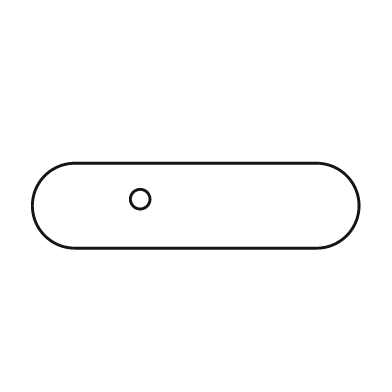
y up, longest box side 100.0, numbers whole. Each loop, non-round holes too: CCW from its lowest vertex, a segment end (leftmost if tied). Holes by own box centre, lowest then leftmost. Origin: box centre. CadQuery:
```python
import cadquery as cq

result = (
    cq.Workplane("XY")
    .moveTo(-37.0, -13.0)
    .lineTo(37.0, -13.0)
    .threePointArc((50.0, 0.0), (37.0, 13.0))
    .lineTo(-37.0, 13.0)
    .threePointArc((-50.0, 0.0), (-37.0, -13.0))
    .close()
    .moveTo(-17.0, 2.0)
    .circle(3.0)
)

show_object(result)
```